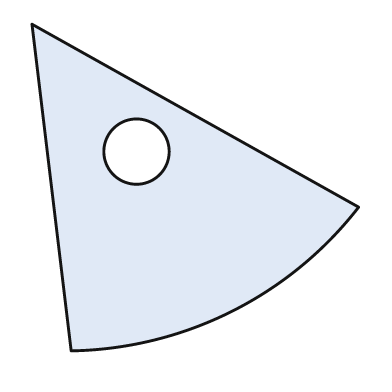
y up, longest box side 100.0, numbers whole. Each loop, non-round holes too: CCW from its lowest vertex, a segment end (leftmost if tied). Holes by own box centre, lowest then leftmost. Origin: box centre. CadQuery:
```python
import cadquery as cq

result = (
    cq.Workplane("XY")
    .moveTo(-38.0, -50.0)
    .threePointArc((11.0, -38.0), (50.0, -6.0))
    .lineTo(-50.0, 50.0)
    .close()
    .moveTo(-18.0, 11.0)
    .circle(10.0)
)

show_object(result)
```